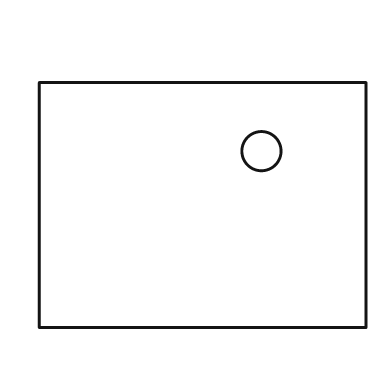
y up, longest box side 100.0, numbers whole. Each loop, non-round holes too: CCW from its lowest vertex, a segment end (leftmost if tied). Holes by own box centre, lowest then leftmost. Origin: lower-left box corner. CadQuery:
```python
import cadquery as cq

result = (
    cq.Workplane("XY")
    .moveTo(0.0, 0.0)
    .lineTo(100.0, 0.0)
    .lineTo(100.0, 75.0)
    .lineTo(0.0, 75.0)
    .close()
    .moveTo(68.0, 54.0)
    .circle(6.0)
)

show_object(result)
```